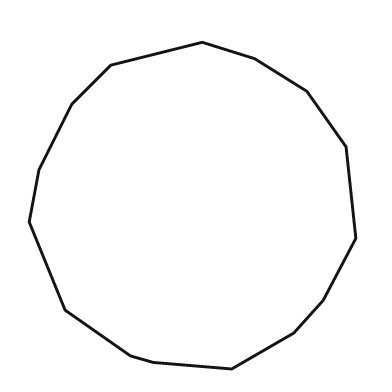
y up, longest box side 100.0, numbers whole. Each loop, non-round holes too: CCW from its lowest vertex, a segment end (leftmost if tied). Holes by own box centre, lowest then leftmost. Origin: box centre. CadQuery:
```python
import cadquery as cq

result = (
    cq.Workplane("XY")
    .moveTo(12.0, -50.0)
    .lineTo(31.0, -39.0)
    .lineTo(40.0, -29.0)
    .lineTo(50.0, -10.0)
    .lineTo(47.0, 18.0)
    .lineTo(35.0, 35.0)
    .lineTo(19.0, 45.0)
    .lineTo(3.0, 50.0)
    .lineTo(-25.0, 43.0)
    .lineTo(-37.0, 31.0)
    .lineTo(-47.0, 11.0)
    .lineTo(-50.0, -5.0)
    .lineTo(-39.0, -32.0)
    .lineTo(-19.0, -46.0)
    .lineTo(-12.0, -48.0)
    .close()
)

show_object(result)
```